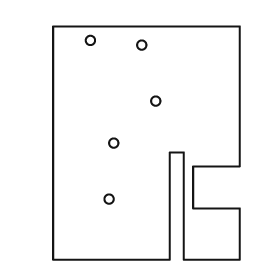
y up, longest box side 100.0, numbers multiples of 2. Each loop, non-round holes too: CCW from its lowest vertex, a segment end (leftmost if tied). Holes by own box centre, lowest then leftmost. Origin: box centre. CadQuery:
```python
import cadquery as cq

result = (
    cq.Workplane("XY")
    .moveTo(-40.0, -50.0)
    .lineTo(10.0, -50.0)
    .lineTo(10.0, -4.0)
    .lineTo(16.0, -4.0)
    .lineTo(16.0, -50.0)
    .lineTo(40.0, -50.0)
    .lineTo(40.0, -28.0)
    .lineTo(20.0, -28.0)
    .lineTo(20.0, -10.0)
    .lineTo(40.0, -10.0)
    .lineTo(40.0, 50.0)
    .lineTo(-40.0, 50.0)
    .close()
    .moveTo(-16.0, -24.0)
    .circle(2.0)
    .moveTo(-14.0, 0.0)
    .circle(2.0)
    .moveTo(4.0, 18.0)
    .circle(2.0)
    .moveTo(-2.0, 42.0)
    .circle(2.0)
    .moveTo(-24.0, 44.0)
    .circle(2.0)
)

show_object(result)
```